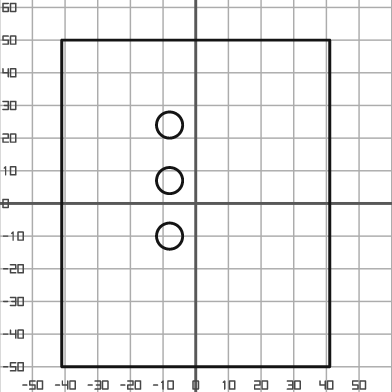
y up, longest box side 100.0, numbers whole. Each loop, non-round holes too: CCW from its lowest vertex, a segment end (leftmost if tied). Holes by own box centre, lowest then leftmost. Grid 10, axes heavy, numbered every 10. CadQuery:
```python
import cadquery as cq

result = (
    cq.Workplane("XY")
    .moveTo(-41.0, -50.0)
    .lineTo(41.0, -50.0)
    .lineTo(41.0, 50.0)
    .lineTo(-41.0, 50.0)
    .close()
    .moveTo(-8.0, -10.0)
    .circle(4.0)
    .moveTo(-8.0, 7.0)
    .circle(4.0)
    .moveTo(-8.0, 24.0)
    .circle(4.0)
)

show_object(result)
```